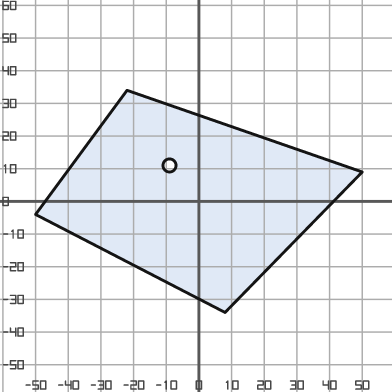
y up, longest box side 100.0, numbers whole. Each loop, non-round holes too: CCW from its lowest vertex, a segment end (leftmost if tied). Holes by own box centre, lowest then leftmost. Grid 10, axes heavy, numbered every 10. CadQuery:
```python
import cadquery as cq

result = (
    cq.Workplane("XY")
    .moveTo(8.0, -34.0)
    .lineTo(50.0, 9.0)
    .lineTo(-22.0, 34.0)
    .lineTo(-50.0, -4.0)
    .close()
    .moveTo(-9.0, 11.0)
    .circle(2.0)
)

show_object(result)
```